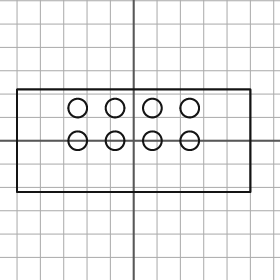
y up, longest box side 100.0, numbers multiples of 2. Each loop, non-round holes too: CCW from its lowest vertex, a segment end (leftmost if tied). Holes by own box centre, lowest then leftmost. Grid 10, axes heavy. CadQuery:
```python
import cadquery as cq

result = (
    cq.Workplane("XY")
    .moveTo(-50.0, -22.0)
    .lineTo(50.0, -22.0)
    .lineTo(50.0, 22.0)
    .lineTo(-50.0, 22.0)
    .close()
    .moveTo(-24.0, 0.0)
    .circle(4.0)
    .moveTo(-8.0, 0.0)
    .circle(4.0)
    .moveTo(8.0, 0.0)
    .circle(4.0)
    .moveTo(24.0, 0.0)
    .circle(4.0)
    .moveTo(-24.0, 14.0)
    .circle(4.0)
    .moveTo(-8.0, 14.0)
    .circle(4.0)
    .moveTo(8.0, 14.0)
    .circle(4.0)
    .moveTo(24.0, 14.0)
    .circle(4.0)
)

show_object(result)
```